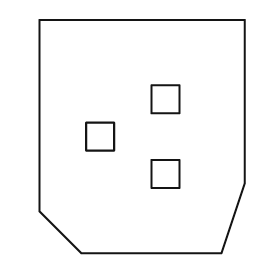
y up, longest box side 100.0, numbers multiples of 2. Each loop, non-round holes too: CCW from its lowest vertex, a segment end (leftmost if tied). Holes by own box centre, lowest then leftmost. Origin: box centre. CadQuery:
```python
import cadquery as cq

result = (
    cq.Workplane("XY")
    .moveTo(-26.0, -50.0)
    .lineTo(34.0, -50.0)
    .lineTo(44.0, -20.0)
    .lineTo(44.0, 50.0)
    .lineTo(-44.0, 50.0)
    .lineTo(-44.0, -32.0)
    .close()
    .moveTo(4.0, -22.0)
    .lineTo(16.0, -22.0)
    .lineTo(16.0, -10.0)
    .lineTo(4.0, -10.0)
    .close()
    .moveTo(-24.0, -6.0)
    .lineTo(-12.0, -6.0)
    .lineTo(-12.0, 6.0)
    .lineTo(-24.0, 6.0)
    .close()
    .moveTo(4.0, 10.0)
    .lineTo(16.0, 10.0)
    .lineTo(16.0, 22.0)
    .lineTo(4.0, 22.0)
    .close()
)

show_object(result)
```